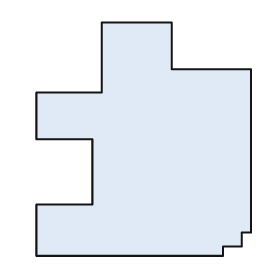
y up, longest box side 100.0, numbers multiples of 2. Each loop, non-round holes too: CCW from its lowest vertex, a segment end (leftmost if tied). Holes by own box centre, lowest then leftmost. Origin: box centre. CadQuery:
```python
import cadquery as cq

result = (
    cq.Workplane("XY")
    .moveTo(-46.0, -50.0)
    .lineTo(34.0, -50.0)
    .lineTo(34.0, -46.0)
    .lineTo(42.0, -46.0)
    .lineTo(42.0, -40.0)
    .lineTo(46.0, -40.0)
    .lineTo(46.0, 30.0)
    .lineTo(12.0, 30.0)
    .lineTo(12.0, 50.0)
    .lineTo(-18.0, 50.0)
    .lineTo(-18.0, 20.0)
    .lineTo(-46.0, 20.0)
    .lineTo(-46.0, 0.0)
    .lineTo(-22.0, 0.0)
    .lineTo(-22.0, -28.0)
    .lineTo(-46.0, -28.0)
    .close()
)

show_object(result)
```